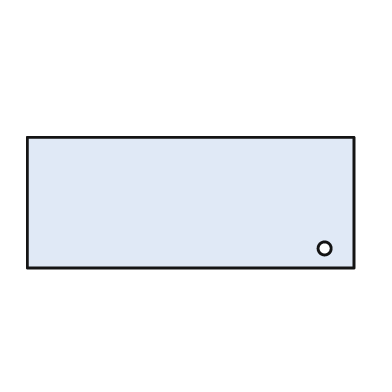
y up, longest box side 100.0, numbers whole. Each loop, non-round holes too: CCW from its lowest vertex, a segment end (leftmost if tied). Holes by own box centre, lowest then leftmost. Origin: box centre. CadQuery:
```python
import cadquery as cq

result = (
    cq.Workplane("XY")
    .moveTo(-50.0, -20.0)
    .lineTo(50.0, -20.0)
    .lineTo(50.0, 20.0)
    .lineTo(-50.0, 20.0)
    .close()
    .moveTo(41.0, -14.0)
    .circle(2.0)
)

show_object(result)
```